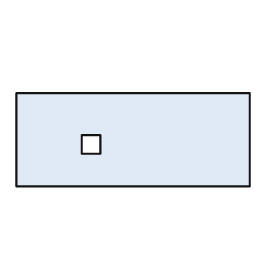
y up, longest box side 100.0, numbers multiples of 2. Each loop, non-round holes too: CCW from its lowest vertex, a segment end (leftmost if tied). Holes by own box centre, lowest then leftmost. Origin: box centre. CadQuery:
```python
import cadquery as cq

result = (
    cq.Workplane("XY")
    .moveTo(-50.0, -20.0)
    .lineTo(50.0, -20.0)
    .lineTo(50.0, 20.0)
    .lineTo(-50.0, 20.0)
    .close()
    .moveTo(-22.0, -6.0)
    .lineTo(-14.0, -6.0)
    .lineTo(-14.0, 2.0)
    .lineTo(-22.0, 2.0)
    .close()
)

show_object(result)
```